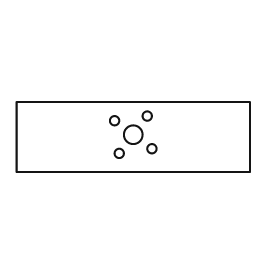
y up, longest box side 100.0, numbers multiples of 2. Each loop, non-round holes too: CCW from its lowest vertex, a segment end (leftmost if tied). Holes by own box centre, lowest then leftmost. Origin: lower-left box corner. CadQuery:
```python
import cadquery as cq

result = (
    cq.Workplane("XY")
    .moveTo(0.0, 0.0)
    .lineTo(100.0, 0.0)
    .lineTo(100.0, 30.0)
    .lineTo(0.0, 30.0)
    .close()
    .moveTo(44.0, 8.0)
    .circle(2.0)
    .moveTo(58.0, 10.0)
    .circle(2.0)
    .moveTo(50.0, 16.0)
    .circle(4.0)
    .moveTo(42.0, 22.0)
    .circle(2.0)
    .moveTo(56.0, 24.0)
    .circle(2.0)
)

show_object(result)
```